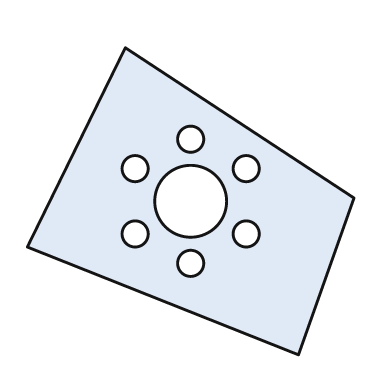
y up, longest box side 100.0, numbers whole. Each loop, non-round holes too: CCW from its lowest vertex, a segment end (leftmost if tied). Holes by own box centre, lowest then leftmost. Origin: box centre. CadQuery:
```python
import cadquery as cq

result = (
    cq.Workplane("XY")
    .moveTo(33.0, -47.0)
    .lineTo(50.0, 1.0)
    .lineTo(-20.0, 47.0)
    .lineTo(-50.0, -14.0)
    .close()
    .moveTo(0.0, -19.0)
    .circle(4.0)
    .moveTo(-17.0, -10.0)
    .circle(4.0)
    .moveTo(17.0, -10.0)
    .circle(4.0)
    .moveTo(0.0, 0.0)
    .circle(11.0)
    .moveTo(-17.0, 10.0)
    .circle(4.0)
    .moveTo(17.0, 10.0)
    .circle(4.0)
    .moveTo(0.0, 19.0)
    .circle(4.0)
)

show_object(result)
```